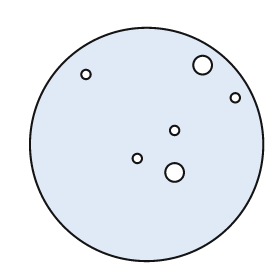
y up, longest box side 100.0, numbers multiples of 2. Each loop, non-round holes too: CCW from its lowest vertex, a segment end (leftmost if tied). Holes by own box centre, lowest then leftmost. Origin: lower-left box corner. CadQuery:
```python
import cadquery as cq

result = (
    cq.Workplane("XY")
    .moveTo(50.0, 50.0)
    .circle(50.0)
    .moveTo(62.0, 38.0)
    .circle(4.0)
    .moveTo(46.0, 44.0)
    .circle(2.0)
    .moveTo(62.0, 56.0)
    .circle(2.0)
    .moveTo(88.0, 70.0)
    .circle(2.0)
    .moveTo(24.0, 80.0)
    .circle(2.0)
    .moveTo(74.0, 84.0)
    .circle(4.0)
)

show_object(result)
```